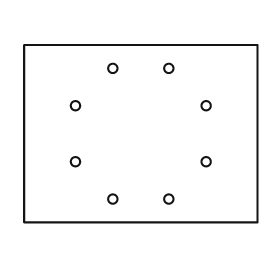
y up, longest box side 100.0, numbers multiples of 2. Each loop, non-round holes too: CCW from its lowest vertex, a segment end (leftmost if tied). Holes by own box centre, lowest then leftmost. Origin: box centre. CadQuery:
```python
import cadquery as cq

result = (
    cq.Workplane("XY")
    .moveTo(-50.0, -38.0)
    .lineTo(50.0, -38.0)
    .lineTo(50.0, 38.0)
    .lineTo(-50.0, 38.0)
    .close()
    .moveTo(-12.0, -28.0)
    .circle(2.0)
    .moveTo(12.0, -28.0)
    .circle(2.0)
    .moveTo(-28.0, -12.0)
    .circle(2.0)
    .moveTo(28.0, -12.0)
    .circle(2.0)
    .moveTo(-28.0, 12.0)
    .circle(2.0)
    .moveTo(28.0, 12.0)
    .circle(2.0)
    .moveTo(-12.0, 28.0)
    .circle(2.0)
    .moveTo(12.0, 28.0)
    .circle(2.0)
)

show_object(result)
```